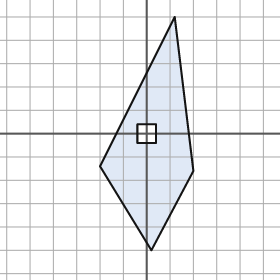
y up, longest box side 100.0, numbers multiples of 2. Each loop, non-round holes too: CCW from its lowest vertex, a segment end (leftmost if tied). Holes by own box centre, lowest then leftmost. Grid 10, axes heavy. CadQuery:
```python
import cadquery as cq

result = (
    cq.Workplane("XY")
    .moveTo(2.0, -50.0)
    .lineTo(20.0, -16.0)
    .lineTo(12.0, 50.0)
    .lineTo(-20.0, -14.0)
    .close()
    .moveTo(-4.0, -4.0)
    .lineTo(4.0, -4.0)
    .lineTo(4.0, 4.0)
    .lineTo(-4.0, 4.0)
    .close()
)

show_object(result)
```